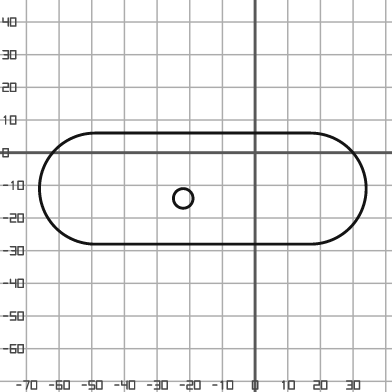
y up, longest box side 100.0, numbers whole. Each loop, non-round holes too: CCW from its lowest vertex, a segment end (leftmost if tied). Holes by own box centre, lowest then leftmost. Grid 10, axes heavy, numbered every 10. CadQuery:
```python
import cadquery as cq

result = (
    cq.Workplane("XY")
    .moveTo(-49.0, -28.0)
    .lineTo(17.0, -28.0)
    .threePointArc((34.0, -11.0), (17.0, 6.0))
    .lineTo(-49.0, 6.0)
    .threePointArc((-66.0, -11.0), (-49.0, -28.0))
    .close()
    .moveTo(-22.0, -14.0)
    .circle(3.0)
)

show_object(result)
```